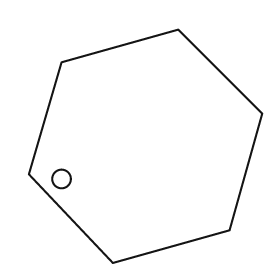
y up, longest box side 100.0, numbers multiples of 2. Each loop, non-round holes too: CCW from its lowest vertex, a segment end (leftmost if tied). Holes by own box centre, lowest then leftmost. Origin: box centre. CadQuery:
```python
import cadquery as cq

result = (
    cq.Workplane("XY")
    .moveTo(-14.0, -50.0)
    .lineTo(36.0, -36.0)
    .lineTo(50.0, 14.0)
    .lineTo(14.0, 50.0)
    .lineTo(-36.0, 36.0)
    .lineTo(-50.0, -12.0)
    .close()
    .moveTo(-36.0, -14.0)
    .circle(4.0)
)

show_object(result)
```